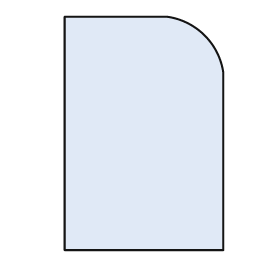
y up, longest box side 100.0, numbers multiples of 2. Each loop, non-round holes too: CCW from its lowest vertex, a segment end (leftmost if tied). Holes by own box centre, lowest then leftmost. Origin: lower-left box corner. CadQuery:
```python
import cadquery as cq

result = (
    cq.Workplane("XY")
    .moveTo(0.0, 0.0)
    .lineTo(68.0, 0.0)
    .lineTo(68.0, 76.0)
    .threePointArc((60.0, 92.0), (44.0, 100.0))
    .lineTo(0.0, 100.0)
    .close()
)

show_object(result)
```